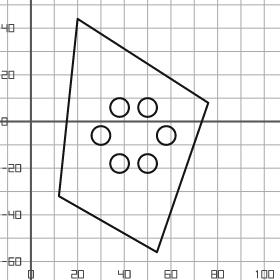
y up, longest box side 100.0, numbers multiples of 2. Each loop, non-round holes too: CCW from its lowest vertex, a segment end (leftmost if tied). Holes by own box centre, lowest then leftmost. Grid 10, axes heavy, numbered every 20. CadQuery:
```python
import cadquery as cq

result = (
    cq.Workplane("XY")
    .moveTo(54.0, -56.0)
    .lineTo(76.0, 8.0)
    .lineTo(20.0, 44.0)
    .lineTo(12.0, -32.0)
    .close()
    .moveTo(38.0, -18.0)
    .circle(4.0)
    .moveTo(50.0, -18.0)
    .circle(4.0)
    .moveTo(30.0, -6.0)
    .circle(4.0)
    .moveTo(58.0, -6.0)
    .circle(4.0)
    .moveTo(38.0, 6.0)
    .circle(4.0)
    .moveTo(50.0, 6.0)
    .circle(4.0)
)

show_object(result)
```